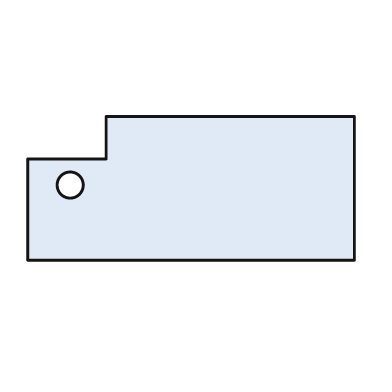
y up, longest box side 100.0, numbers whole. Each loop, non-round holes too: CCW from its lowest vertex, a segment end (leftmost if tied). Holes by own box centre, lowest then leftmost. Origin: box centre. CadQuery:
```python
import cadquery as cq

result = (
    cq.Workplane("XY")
    .moveTo(-50.0, -22.0)
    .lineTo(50.0, -22.0)
    .lineTo(50.0, 22.0)
    .lineTo(-26.0, 22.0)
    .lineTo(-26.0, 9.0)
    .lineTo(-50.0, 9.0)
    .close()
    .moveTo(-37.0, 1.0)
    .circle(4.0)
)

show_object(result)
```